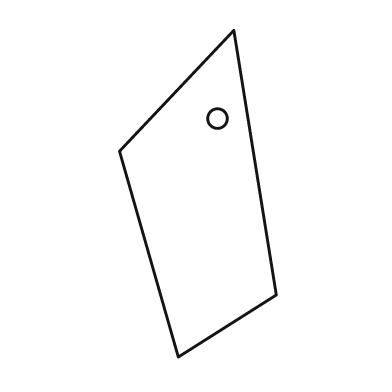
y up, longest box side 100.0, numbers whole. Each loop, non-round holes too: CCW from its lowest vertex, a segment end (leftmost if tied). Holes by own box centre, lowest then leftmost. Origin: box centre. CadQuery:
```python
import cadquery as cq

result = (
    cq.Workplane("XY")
    .moveTo(-6.0, -50.0)
    .lineTo(24.0, -31.0)
    .lineTo(11.0, 50.0)
    .lineTo(-24.0, 13.0)
    .close()
    .moveTo(6.0, 23.0)
    .circle(3.0)
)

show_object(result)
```